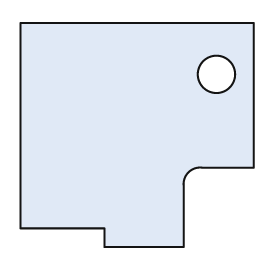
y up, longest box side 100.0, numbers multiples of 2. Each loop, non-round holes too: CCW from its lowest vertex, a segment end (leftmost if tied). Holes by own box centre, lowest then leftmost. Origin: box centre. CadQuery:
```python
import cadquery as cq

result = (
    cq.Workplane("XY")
    .moveTo(-14.0, -48.0)
    .lineTo(20.0, -48.0)
    .lineTo(20.0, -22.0)
    .threePointArc((22.0, -16.0), (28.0, -14.0))
    .lineTo(50.0, -14.0)
    .lineTo(50.0, 48.0)
    .lineTo(-50.0, 48.0)
    .lineTo(-50.0, -40.0)
    .lineTo(-14.0, -40.0)
    .close()
    .moveTo(34.0, 26.0)
    .circle(8.0)
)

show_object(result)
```